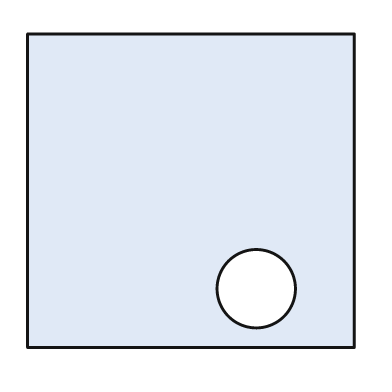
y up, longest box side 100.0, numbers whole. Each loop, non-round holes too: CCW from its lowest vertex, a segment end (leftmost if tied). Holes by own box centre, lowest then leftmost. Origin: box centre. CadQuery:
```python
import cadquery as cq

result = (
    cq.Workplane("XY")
    .moveTo(-50.0, -48.0)
    .lineTo(50.0, -48.0)
    .lineTo(50.0, 48.0)
    .lineTo(-50.0, 48.0)
    .close()
    .moveTo(20.0, -30.0)
    .circle(12.0)
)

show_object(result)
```